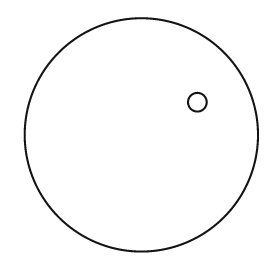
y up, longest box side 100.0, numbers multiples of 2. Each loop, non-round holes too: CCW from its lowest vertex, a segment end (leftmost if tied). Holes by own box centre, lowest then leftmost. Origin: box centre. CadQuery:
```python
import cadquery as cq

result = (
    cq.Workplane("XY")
    .moveTo(0.0, 0.0)
    .circle(50.0)
    .moveTo(24.0, 14.0)
    .circle(4.0)
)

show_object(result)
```